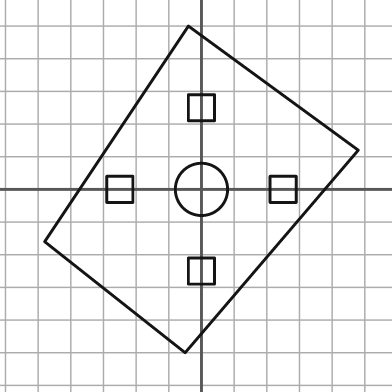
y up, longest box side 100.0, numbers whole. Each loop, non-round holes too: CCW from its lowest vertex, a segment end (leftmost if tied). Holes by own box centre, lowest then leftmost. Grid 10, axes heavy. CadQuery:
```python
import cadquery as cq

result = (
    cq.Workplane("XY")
    .moveTo(-5.0, -50.0)
    .lineTo(48.0, 12.0)
    .lineTo(-4.0, 50.0)
    .lineTo(-48.0, -16.0)
    .close()
    .moveTo(-4.0, -29.0)
    .lineTo(4.0, -29.0)
    .lineTo(4.0, -21.0)
    .lineTo(-4.0, -21.0)
    .close()
    .moveTo(-29.0, -4.0)
    .lineTo(-21.0, -4.0)
    .lineTo(-21.0, 4.0)
    .lineTo(-29.0, 4.0)
    .close()
    .moveTo(0.0, 0.0)
    .circle(8.0)
    .moveTo(21.0, -4.0)
    .lineTo(29.0, -4.0)
    .lineTo(29.0, 4.0)
    .lineTo(21.0, 4.0)
    .close()
    .moveTo(-4.0, 21.0)
    .lineTo(4.0, 21.0)
    .lineTo(4.0, 29.0)
    .lineTo(-4.0, 29.0)
    .close()
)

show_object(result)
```